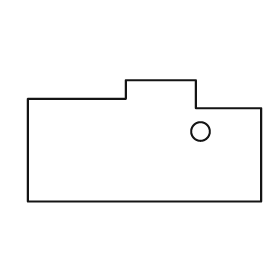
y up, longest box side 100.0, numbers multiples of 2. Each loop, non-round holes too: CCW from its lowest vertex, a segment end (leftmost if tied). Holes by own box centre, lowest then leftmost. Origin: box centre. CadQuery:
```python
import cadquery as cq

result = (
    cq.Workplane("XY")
    .moveTo(-50.0, -26.0)
    .lineTo(50.0, -26.0)
    .lineTo(50.0, 14.0)
    .lineTo(22.0, 14.0)
    .lineTo(22.0, 26.0)
    .lineTo(-8.0, 26.0)
    .lineTo(-8.0, 18.0)
    .lineTo(-50.0, 18.0)
    .close()
    .moveTo(24.0, 4.0)
    .circle(4.0)
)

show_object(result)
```